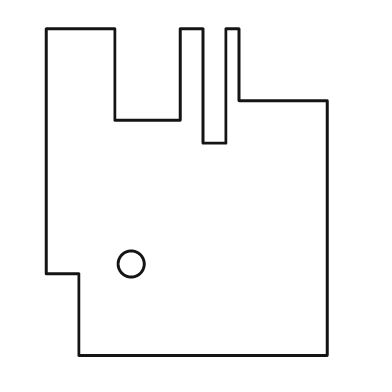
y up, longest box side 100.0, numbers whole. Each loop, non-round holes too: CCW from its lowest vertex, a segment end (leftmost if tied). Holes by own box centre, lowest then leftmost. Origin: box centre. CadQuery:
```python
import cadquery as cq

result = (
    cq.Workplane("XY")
    .moveTo(-33.0, -50.0)
    .lineTo(43.0, -50.0)
    .lineTo(43.0, 28.0)
    .lineTo(16.0, 28.0)
    .lineTo(16.0, 50.0)
    .lineTo(12.0, 50.0)
    .lineTo(12.0, 15.0)
    .lineTo(5.0, 15.0)
    .lineTo(5.0, 50.0)
    .lineTo(-2.0, 50.0)
    .lineTo(-2.0, 22.0)
    .lineTo(-22.0, 22.0)
    .lineTo(-22.0, 50.0)
    .lineTo(-43.0, 50.0)
    .lineTo(-43.0, -25.0)
    .lineTo(-33.0, -25.0)
    .close()
    .moveTo(-17.0, -22.0)
    .circle(4.0)
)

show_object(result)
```